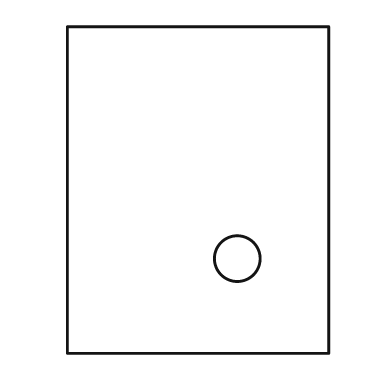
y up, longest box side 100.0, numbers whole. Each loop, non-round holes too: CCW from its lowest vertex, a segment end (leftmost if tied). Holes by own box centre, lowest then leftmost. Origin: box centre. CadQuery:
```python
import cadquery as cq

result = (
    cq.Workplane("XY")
    .moveTo(-40.0, -50.0)
    .lineTo(40.0, -50.0)
    .lineTo(40.0, 50.0)
    .lineTo(-40.0, 50.0)
    .close()
    .moveTo(12.0, -21.0)
    .circle(7.0)
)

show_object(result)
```